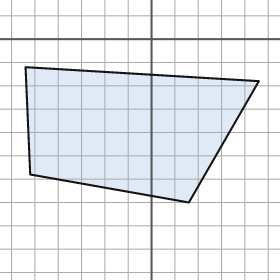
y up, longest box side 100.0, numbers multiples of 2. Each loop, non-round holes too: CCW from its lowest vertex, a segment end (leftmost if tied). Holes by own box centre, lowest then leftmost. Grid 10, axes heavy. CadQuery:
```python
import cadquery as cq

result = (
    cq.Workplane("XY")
    .moveTo(16.0, -70.0)
    .lineTo(46.0, -18.0)
    .lineTo(-54.0, -12.0)
    .lineTo(-52.0, -58.0)
    .close()
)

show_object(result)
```